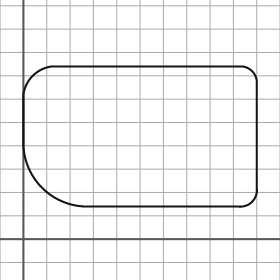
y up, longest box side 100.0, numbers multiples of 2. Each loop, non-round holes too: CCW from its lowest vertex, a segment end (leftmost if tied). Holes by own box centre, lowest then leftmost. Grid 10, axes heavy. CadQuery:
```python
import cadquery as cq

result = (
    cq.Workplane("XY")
    .moveTo(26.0, 14.0)
    .lineTo(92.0, 14.0)
    .threePointArc((98.0, 16.0), (100.0, 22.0))
    .lineTo(100.0, 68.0)
    .threePointArc((98.0, 72.0), (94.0, 74.0))
    .lineTo(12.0, 74.0)
    .threePointArc((4.0, 70.0), (0.0, 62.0))
    .lineTo(0.0, 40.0)
    .threePointArc((8.0, 22.0), (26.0, 14.0))
    .close()
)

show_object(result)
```